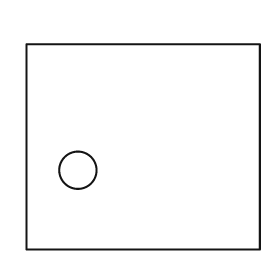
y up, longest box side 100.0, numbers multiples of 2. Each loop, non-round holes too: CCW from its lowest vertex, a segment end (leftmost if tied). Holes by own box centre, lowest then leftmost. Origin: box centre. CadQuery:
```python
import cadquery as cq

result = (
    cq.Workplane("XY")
    .moveTo(-50.0, -44.0)
    .lineTo(50.0, -44.0)
    .lineTo(50.0, 44.0)
    .lineTo(-50.0, 44.0)
    .close()
    .moveTo(-28.0, -10.0)
    .circle(8.0)
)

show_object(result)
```